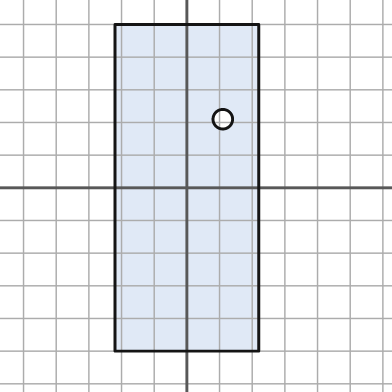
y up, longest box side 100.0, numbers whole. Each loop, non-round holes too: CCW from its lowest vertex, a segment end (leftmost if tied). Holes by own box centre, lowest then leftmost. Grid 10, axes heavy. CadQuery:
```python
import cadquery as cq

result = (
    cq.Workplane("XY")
    .moveTo(-22.0, -50.0)
    .lineTo(22.0, -50.0)
    .lineTo(22.0, 50.0)
    .lineTo(-22.0, 50.0)
    .close()
    .moveTo(11.0, 21.0)
    .circle(3.0)
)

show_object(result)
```